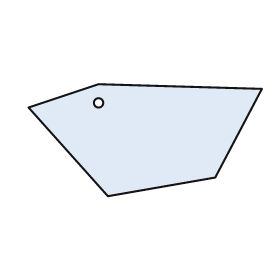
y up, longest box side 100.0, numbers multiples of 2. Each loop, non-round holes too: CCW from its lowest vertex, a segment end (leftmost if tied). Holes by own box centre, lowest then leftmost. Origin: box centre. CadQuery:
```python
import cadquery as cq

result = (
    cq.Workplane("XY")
    .moveTo(-16.0, -24.0)
    .lineTo(30.0, -16.0)
    .lineTo(50.0, 22.0)
    .lineTo(-20.0, 24.0)
    .lineTo(-50.0, 14.0)
    .close()
    .moveTo(-20.0, 16.0)
    .circle(2.0)
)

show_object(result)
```